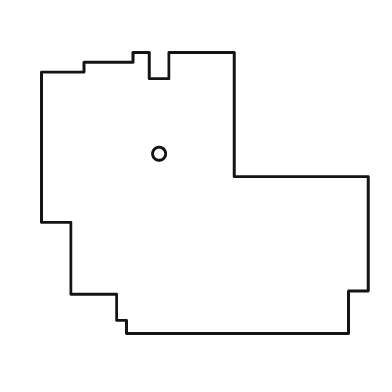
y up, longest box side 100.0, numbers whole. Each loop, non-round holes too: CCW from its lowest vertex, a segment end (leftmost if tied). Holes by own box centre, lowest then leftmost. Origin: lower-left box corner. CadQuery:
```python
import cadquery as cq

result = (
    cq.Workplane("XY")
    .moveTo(26.0, 0.0)
    .lineTo(94.0, 0.0)
    .lineTo(94.0, 13.0)
    .lineTo(100.0, 13.0)
    .lineTo(100.0, 48.0)
    .lineTo(59.0, 48.0)
    .lineTo(59.0, 86.0)
    .lineTo(39.0, 86.0)
    .lineTo(39.0, 78.0)
    .lineTo(33.0, 78.0)
    .lineTo(33.0, 86.0)
    .lineTo(28.0, 86.0)
    .lineTo(28.0, 83.0)
    .lineTo(13.0, 83.0)
    .lineTo(13.0, 80.0)
    .lineTo(0.0, 80.0)
    .lineTo(0.0, 34.0)
    .lineTo(9.0, 34.0)
    .lineTo(9.0, 12.0)
    .lineTo(23.0, 12.0)
    .lineTo(23.0, 4.0)
    .lineTo(26.0, 4.0)
    .close()
    .moveTo(36.0, 55.0)
    .circle(2.0)
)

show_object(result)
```